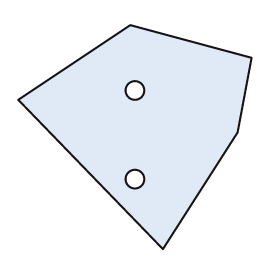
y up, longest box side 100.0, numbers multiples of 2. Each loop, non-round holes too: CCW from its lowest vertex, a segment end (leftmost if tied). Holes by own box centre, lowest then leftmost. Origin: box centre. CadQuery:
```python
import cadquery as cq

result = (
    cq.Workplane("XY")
    .moveTo(12.0, -48.0)
    .lineTo(44.0, 2.0)
    .lineTo(50.0, 34.0)
    .lineTo(-2.0, 48.0)
    .lineTo(-50.0, 16.0)
    .close()
    .moveTo(0.0, -18.0)
    .circle(4.0)
    .moveTo(0.0, 20.0)
    .circle(4.0)
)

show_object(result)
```